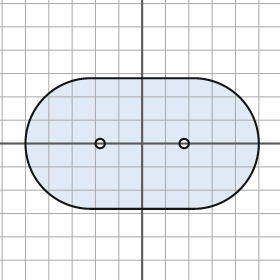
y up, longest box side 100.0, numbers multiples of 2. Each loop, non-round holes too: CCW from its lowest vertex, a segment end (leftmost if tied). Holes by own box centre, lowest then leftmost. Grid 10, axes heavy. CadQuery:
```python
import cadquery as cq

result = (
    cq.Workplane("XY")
    .moveTo(-22.0, -28.0)
    .lineTo(22.0, -28.0)
    .threePointArc((50.0, 0.0), (22.0, 28.0))
    .lineTo(-22.0, 28.0)
    .threePointArc((-50.0, 0.0), (-22.0, -28.0))
    .close()
    .moveTo(-18.0, 0.0)
    .circle(2.0)
    .moveTo(18.0, 0.0)
    .circle(2.0)
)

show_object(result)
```